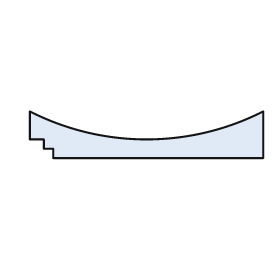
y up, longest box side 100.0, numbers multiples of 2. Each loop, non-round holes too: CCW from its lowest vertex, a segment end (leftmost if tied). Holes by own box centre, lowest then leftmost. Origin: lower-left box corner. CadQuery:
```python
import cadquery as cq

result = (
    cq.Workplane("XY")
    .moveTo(10.0, 0.0)
    .lineTo(100.0, 0.0)
    .lineTo(100.0, 20.0)
    .threePointArc((50.0, 8.0), (0.0, 20.0))
    .lineTo(0.0, 8.0)
    .lineTo(6.0, 8.0)
    .lineTo(6.0, 4.0)
    .lineTo(10.0, 4.0)
    .close()
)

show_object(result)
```